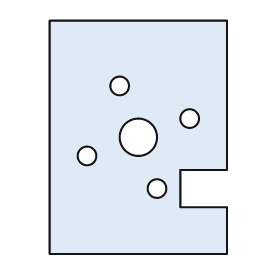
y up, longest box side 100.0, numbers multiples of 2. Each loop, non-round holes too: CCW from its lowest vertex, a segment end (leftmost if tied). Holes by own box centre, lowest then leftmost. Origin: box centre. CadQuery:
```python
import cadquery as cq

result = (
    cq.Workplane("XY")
    .moveTo(-38.0, -50.0)
    .lineTo(38.0, -50.0)
    .lineTo(38.0, -30.0)
    .lineTo(18.0, -30.0)
    .lineTo(18.0, -14.0)
    .lineTo(38.0, -14.0)
    .lineTo(38.0, 50.0)
    .lineTo(-38.0, 50.0)
    .close()
    .moveTo(8.0, -22.0)
    .circle(4.0)
    .moveTo(-22.0, -8.0)
    .circle(4.0)
    .moveTo(0.0, 0.0)
    .circle(8.0)
    .moveTo(22.0, 8.0)
    .circle(4.0)
    .moveTo(-8.0, 22.0)
    .circle(4.0)
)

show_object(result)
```